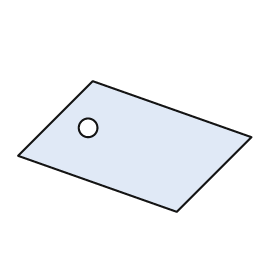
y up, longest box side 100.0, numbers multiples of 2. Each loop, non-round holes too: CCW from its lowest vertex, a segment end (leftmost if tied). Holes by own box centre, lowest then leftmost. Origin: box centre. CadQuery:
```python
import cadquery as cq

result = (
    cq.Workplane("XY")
    .moveTo(18.0, -28.0)
    .lineTo(50.0, 4.0)
    .lineTo(-18.0, 28.0)
    .lineTo(-50.0, -4.0)
    .close()
    .moveTo(-20.0, 8.0)
    .circle(4.0)
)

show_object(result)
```